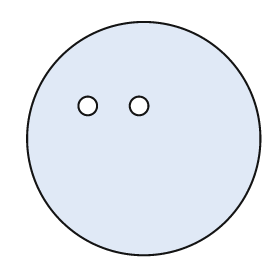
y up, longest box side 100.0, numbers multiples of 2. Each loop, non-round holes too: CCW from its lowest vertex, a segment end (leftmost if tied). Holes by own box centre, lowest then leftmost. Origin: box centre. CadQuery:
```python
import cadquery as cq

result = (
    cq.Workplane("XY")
    .moveTo(0.0, 0.0)
    .circle(50.0)
    .moveTo(-24.0, 14.0)
    .circle(4.0)
    .moveTo(-2.0, 14.0)
    .circle(4.0)
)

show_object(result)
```